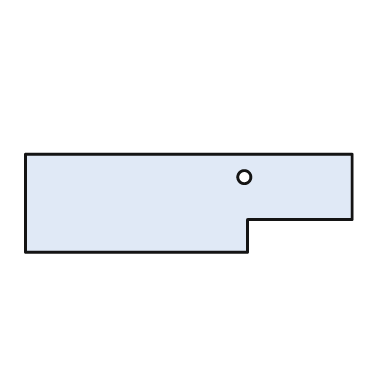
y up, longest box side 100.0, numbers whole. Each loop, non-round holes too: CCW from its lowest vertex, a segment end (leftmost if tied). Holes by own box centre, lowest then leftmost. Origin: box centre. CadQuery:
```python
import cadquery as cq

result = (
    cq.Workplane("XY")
    .moveTo(-50.0, -15.0)
    .lineTo(18.0, -15.0)
    .lineTo(18.0, -5.0)
    .lineTo(50.0, -5.0)
    .lineTo(50.0, 15.0)
    .lineTo(-50.0, 15.0)
    .close()
    .moveTo(17.0, 8.0)
    .circle(2.0)
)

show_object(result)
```